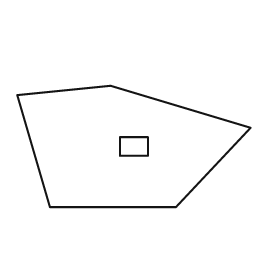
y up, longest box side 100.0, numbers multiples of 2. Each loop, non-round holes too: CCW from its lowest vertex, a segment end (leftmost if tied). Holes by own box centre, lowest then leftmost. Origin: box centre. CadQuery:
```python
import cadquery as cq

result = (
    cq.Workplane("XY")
    .moveTo(-36.0, -26.0)
    .lineTo(18.0, -26.0)
    .lineTo(50.0, 8.0)
    .lineTo(-10.0, 26.0)
    .lineTo(-50.0, 22.0)
    .close()
    .moveTo(-6.0, -4.0)
    .lineTo(6.0, -4.0)
    .lineTo(6.0, 4.0)
    .lineTo(-6.0, 4.0)
    .close()
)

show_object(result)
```